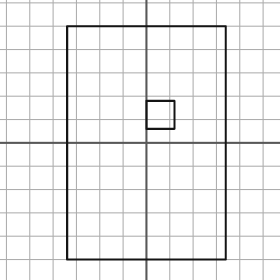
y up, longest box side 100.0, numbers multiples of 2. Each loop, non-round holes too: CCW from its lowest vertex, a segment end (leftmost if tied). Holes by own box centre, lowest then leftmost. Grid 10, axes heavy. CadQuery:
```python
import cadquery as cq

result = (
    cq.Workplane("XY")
    .moveTo(-34.0, -50.0)
    .lineTo(34.0, -50.0)
    .lineTo(34.0, 50.0)
    .lineTo(-34.0, 50.0)
    .close()
    .moveTo(0.0, 6.0)
    .lineTo(12.0, 6.0)
    .lineTo(12.0, 18.0)
    .lineTo(0.0, 18.0)
    .close()
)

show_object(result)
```